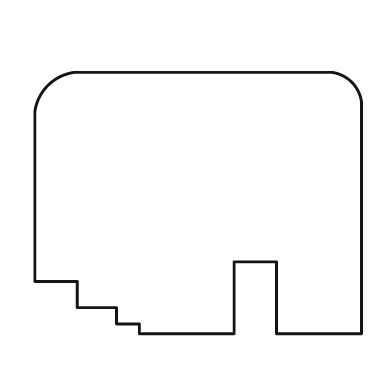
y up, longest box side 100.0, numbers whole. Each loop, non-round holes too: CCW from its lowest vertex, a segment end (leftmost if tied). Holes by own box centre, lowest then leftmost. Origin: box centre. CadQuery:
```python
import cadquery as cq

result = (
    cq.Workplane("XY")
    .moveTo(-18.0, -40.0)
    .lineTo(11.0, -40.0)
    .lineTo(11.0, -18.0)
    .lineTo(24.0, -18.0)
    .lineTo(24.0, -40.0)
    .lineTo(50.0, -40.0)
    .lineTo(50.0, 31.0)
    .threePointArc((47.0, 37.0), (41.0, 40.0))
    .lineTo(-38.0, 40.0)
    .threePointArc((-46.0, 36.0), (-50.0, 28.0))
    .lineTo(-50.0, -24.0)
    .lineTo(-37.0, -24.0)
    .lineTo(-37.0, -32.0)
    .lineTo(-25.0, -32.0)
    .lineTo(-25.0, -37.0)
    .lineTo(-18.0, -37.0)
    .close()
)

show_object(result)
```